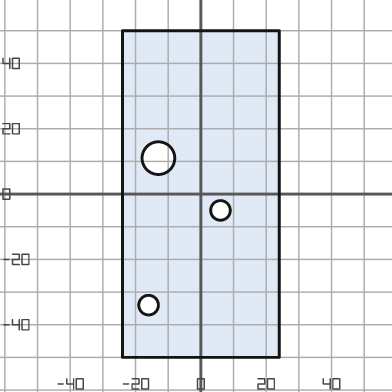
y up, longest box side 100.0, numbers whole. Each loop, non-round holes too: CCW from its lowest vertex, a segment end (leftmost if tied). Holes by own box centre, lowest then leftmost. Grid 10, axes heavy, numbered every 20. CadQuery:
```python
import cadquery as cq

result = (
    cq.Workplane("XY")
    .moveTo(-24.0, -50.0)
    .lineTo(24.0, -50.0)
    .lineTo(24.0, 50.0)
    .lineTo(-24.0, 50.0)
    .close()
    .moveTo(-16.0, -34.0)
    .circle(3.0)
    .moveTo(6.0, -5.0)
    .circle(3.0)
    .moveTo(-13.0, 11.0)
    .circle(5.0)
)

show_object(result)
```